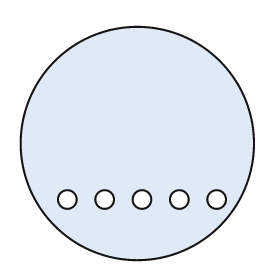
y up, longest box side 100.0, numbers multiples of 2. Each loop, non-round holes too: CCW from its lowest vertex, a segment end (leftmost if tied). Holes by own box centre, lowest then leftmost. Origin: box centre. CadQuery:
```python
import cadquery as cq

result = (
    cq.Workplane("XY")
    .moveTo(0.0, 0.0)
    .circle(50.0)
    .moveTo(-30.0, -24.0)
    .circle(4.0)
    .moveTo(-14.0, -24.0)
    .circle(4.0)
    .moveTo(2.0, -24.0)
    .circle(4.0)
    .moveTo(18.0, -24.0)
    .circle(4.0)
    .moveTo(34.0, -24.0)
    .circle(4.0)
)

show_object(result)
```